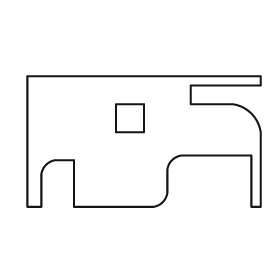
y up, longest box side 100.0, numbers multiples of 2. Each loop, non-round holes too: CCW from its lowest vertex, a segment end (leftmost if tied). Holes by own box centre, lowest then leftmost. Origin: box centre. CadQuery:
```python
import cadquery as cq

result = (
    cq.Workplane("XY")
    .moveTo(-50.0, -28.0)
    .lineTo(-44.0, -28.0)
    .lineTo(-44.0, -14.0)
    .threePointArc((-42.0, -10.0), (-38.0, -8.0))
    .lineTo(-30.0, -8.0)
    .lineTo(-30.0, -28.0)
    .lineTo(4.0, -28.0)
    .threePointArc((8.0, -26.0), (10.0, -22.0))
    .lineTo(10.0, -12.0)
    .threePointArc((12.0, -8.0), (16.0, -6.0))
    .lineTo(46.0, -6.0)
    .lineTo(46.0, -28.0)
    .lineTo(50.0, -28.0)
    .lineTo(50.0, 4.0)
    .threePointArc((46.0, 12.0), (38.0, 16.0))
    .lineTo(20.0, 16.0)
    .lineTo(20.0, 24.0)
    .lineTo(50.0, 24.0)
    .lineTo(50.0, 28.0)
    .lineTo(-50.0, 28.0)
    .close()
    .moveTo(-12.0, 4.0)
    .lineTo(0.0, 4.0)
    .lineTo(0.0, 16.0)
    .lineTo(-12.0, 16.0)
    .close()
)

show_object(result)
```